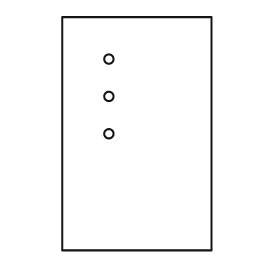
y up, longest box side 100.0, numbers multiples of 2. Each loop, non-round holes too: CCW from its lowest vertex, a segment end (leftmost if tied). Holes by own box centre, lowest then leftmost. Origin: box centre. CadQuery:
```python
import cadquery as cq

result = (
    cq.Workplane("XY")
    .moveTo(-32.0, -50.0)
    .lineTo(32.0, -50.0)
    .lineTo(32.0, 50.0)
    .lineTo(-32.0, 50.0)
    .close()
    .moveTo(-12.0, 0.0)
    .circle(2.0)
    .moveTo(-12.0, 16.0)
    .circle(2.0)
    .moveTo(-12.0, 32.0)
    .circle(2.0)
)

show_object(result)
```